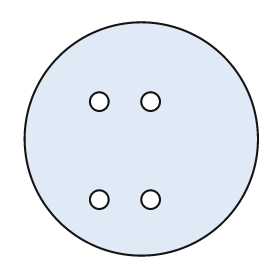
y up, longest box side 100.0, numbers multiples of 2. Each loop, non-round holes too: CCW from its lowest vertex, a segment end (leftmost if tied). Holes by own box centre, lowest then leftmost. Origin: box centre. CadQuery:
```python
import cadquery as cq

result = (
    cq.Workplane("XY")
    .moveTo(0.0, 0.0)
    .circle(50.0)
    .moveTo(-18.0, -26.0)
    .circle(4.0)
    .moveTo(4.0, -26.0)
    .circle(4.0)
    .moveTo(-18.0, 16.0)
    .circle(4.0)
    .moveTo(4.0, 16.0)
    .circle(4.0)
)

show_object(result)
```